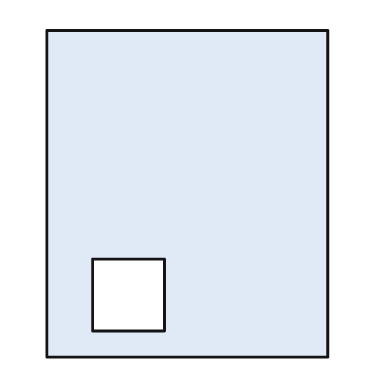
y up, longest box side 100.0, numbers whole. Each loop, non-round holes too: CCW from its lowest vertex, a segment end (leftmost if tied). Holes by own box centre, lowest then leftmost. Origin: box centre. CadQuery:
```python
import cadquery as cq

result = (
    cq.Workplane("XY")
    .moveTo(-43.0, -50.0)
    .lineTo(43.0, -50.0)
    .lineTo(43.0, 50.0)
    .lineTo(-43.0, 50.0)
    .close()
    .moveTo(-29.0, -42.0)
    .lineTo(-7.0, -42.0)
    .lineTo(-7.0, -20.0)
    .lineTo(-29.0, -20.0)
    .close()
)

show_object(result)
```